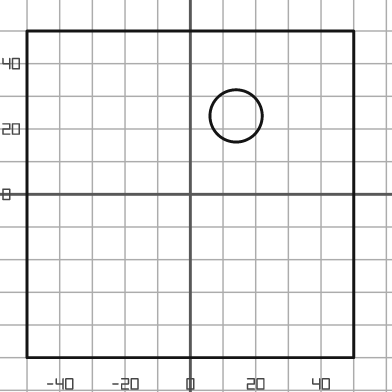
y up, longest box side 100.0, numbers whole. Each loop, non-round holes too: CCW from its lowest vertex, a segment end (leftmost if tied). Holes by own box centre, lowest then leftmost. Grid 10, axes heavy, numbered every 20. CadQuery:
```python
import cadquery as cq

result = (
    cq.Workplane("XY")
    .moveTo(-50.0, -50.0)
    .lineTo(50.0, -50.0)
    .lineTo(50.0, 50.0)
    .lineTo(-50.0, 50.0)
    .close()
    .moveTo(14.0, 24.0)
    .circle(8.0)
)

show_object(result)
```